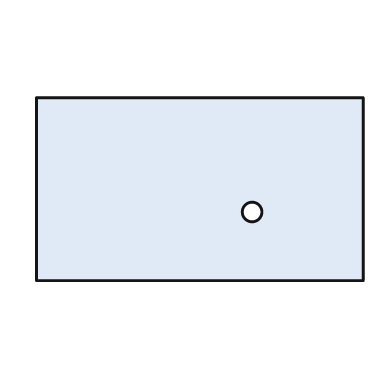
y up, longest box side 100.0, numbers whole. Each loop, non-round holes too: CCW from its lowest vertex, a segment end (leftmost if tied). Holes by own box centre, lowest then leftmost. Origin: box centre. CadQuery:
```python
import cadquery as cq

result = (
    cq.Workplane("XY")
    .moveTo(-50.0, -28.0)
    .lineTo(50.0, -28.0)
    .lineTo(50.0, 28.0)
    .lineTo(-50.0, 28.0)
    .close()
    .moveTo(16.0, -7.0)
    .circle(3.0)
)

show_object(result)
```